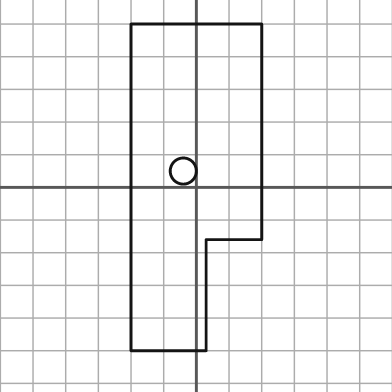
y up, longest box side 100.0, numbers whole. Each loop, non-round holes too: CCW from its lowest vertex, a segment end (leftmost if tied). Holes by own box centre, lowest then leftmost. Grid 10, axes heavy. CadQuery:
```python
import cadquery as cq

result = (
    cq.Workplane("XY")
    .moveTo(-20.0, -50.0)
    .lineTo(3.0, -50.0)
    .lineTo(3.0, -16.0)
    .lineTo(20.0, -16.0)
    .lineTo(20.0, 50.0)
    .lineTo(-20.0, 50.0)
    .close()
    .moveTo(-4.0, 5.0)
    .circle(4.0)
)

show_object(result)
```